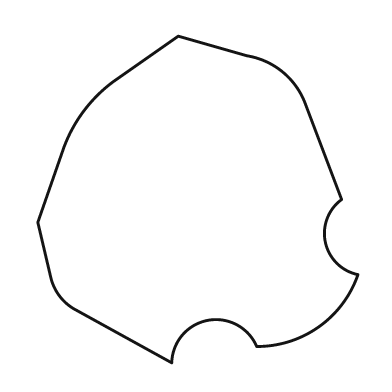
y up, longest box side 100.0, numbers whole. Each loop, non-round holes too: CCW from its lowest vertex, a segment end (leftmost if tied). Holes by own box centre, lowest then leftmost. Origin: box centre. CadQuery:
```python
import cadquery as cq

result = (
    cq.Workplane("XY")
    .moveTo(-8.0, -50.0)
    .threePointArc((3.0, -37.0), (18.0, -45.0))
    .threePointArc((37.0, -39.0), (49.0, -23.0))
    .threePointArc((39.0, -13.0), (44.0, 0.0))
    .lineTo(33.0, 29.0)
    .threePointArc((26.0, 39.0), (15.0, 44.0))
    .lineTo(-6.0, 50.0)
    .lineTo(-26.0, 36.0)
    .threePointArc((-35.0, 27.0), (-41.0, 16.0))
    .lineTo(-49.0, -7.0)
    .lineTo(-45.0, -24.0)
    .threePointArc((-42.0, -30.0), (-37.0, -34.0))
    .close()
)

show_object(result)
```